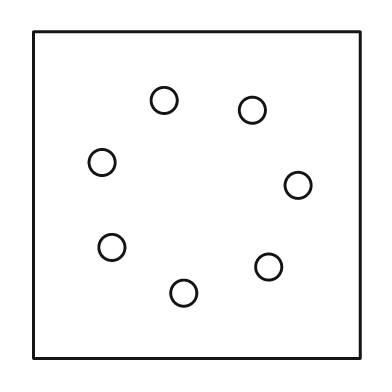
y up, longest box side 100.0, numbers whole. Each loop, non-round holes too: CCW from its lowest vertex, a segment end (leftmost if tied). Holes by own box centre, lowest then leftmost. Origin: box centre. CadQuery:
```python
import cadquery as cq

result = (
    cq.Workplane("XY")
    .moveTo(-50.0, -50.0)
    .lineTo(50.0, -50.0)
    .lineTo(50.0, 50.0)
    .lineTo(-50.0, 50.0)
    .close()
    .moveTo(-4.0, -30.0)
    .circle(4.0)
    .moveTo(22.0, -22.0)
    .circle(4.0)
    .moveTo(-26.0, -16.0)
    .circle(4.0)
    .moveTo(31.0, 3.0)
    .circle(4.0)
    .moveTo(-29.0, 10.0)
    .circle(4.0)
    .moveTo(17.0, 26.0)
    .circle(4.0)
    .moveTo(-10.0, 29.0)
    .circle(4.0)
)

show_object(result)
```